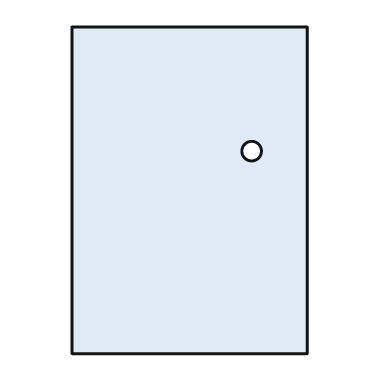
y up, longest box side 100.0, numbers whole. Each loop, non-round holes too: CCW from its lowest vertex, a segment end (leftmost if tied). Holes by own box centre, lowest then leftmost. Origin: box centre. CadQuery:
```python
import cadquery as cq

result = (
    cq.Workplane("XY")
    .moveTo(-36.0, -50.0)
    .lineTo(36.0, -50.0)
    .lineTo(36.0, 50.0)
    .lineTo(-36.0, 50.0)
    .close()
    .moveTo(19.0, 12.0)
    .circle(3.0)
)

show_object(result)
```